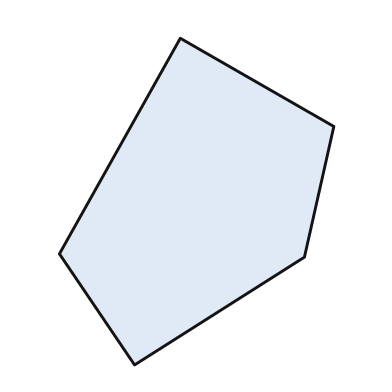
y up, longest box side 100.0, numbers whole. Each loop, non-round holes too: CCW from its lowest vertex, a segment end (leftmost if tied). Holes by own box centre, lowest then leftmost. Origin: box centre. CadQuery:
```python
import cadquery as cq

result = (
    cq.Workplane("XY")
    .moveTo(-19.0, -50.0)
    .lineTo(33.0, -17.0)
    .lineTo(42.0, 23.0)
    .lineTo(-5.0, 50.0)
    .lineTo(-42.0, -16.0)
    .close()
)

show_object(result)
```